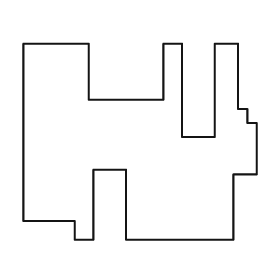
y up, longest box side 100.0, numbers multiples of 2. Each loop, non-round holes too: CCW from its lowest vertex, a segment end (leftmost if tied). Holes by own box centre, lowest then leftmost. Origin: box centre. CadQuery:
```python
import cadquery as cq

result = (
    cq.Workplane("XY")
    .moveTo(-28.0, -42.0)
    .lineTo(-20.0, -42.0)
    .lineTo(-20.0, -12.0)
    .lineTo(-6.0, -12.0)
    .lineTo(-6.0, -42.0)
    .lineTo(40.0, -42.0)
    .lineTo(40.0, -14.0)
    .lineTo(50.0, -14.0)
    .lineTo(50.0, 8.0)
    .lineTo(46.0, 8.0)
    .lineTo(46.0, 14.0)
    .lineTo(42.0, 14.0)
    .lineTo(42.0, 42.0)
    .lineTo(32.0, 42.0)
    .lineTo(32.0, 2.0)
    .lineTo(18.0, 2.0)
    .lineTo(18.0, 42.0)
    .lineTo(10.0, 42.0)
    .lineTo(10.0, 18.0)
    .lineTo(-22.0, 18.0)
    .lineTo(-22.0, 42.0)
    .lineTo(-50.0, 42.0)
    .lineTo(-50.0, -34.0)
    .lineTo(-28.0, -34.0)
    .close()
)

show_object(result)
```